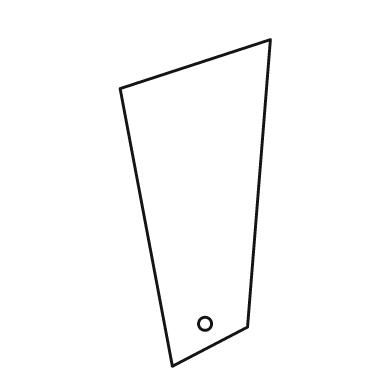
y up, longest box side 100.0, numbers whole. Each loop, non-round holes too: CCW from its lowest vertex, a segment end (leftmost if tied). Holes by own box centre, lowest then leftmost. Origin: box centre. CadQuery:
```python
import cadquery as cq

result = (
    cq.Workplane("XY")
    .moveTo(-7.0, -50.0)
    .lineTo(16.0, -38.0)
    .lineTo(23.0, 50.0)
    .lineTo(-23.0, 35.0)
    .close()
    .moveTo(3.0, -37.0)
    .circle(2.0)
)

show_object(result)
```